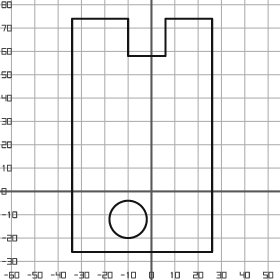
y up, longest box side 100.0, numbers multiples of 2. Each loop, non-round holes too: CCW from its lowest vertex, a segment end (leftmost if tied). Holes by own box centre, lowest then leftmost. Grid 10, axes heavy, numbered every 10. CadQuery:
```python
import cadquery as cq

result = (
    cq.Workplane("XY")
    .moveTo(-34.0, -26.0)
    .lineTo(26.0, -26.0)
    .lineTo(26.0, 74.0)
    .lineTo(6.0, 74.0)
    .lineTo(6.0, 58.0)
    .lineTo(-10.0, 58.0)
    .lineTo(-10.0, 74.0)
    .lineTo(-34.0, 74.0)
    .close()
    .moveTo(-10.0, -12.0)
    .circle(8.0)
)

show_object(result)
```